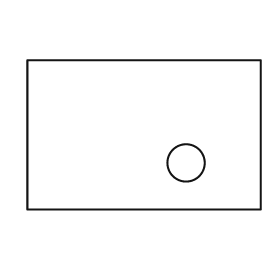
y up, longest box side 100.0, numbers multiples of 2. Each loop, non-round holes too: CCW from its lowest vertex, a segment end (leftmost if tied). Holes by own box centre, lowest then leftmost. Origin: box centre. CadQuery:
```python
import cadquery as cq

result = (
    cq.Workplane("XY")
    .moveTo(-50.0, -32.0)
    .lineTo(50.0, -32.0)
    .lineTo(50.0, 32.0)
    .lineTo(-50.0, 32.0)
    .close()
    .moveTo(18.0, -12.0)
    .circle(8.0)
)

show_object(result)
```